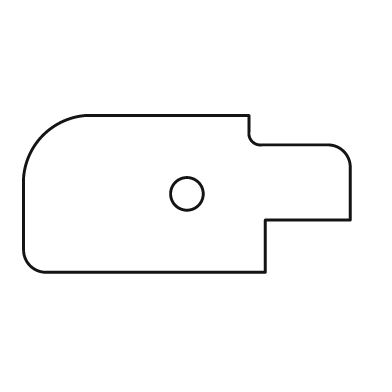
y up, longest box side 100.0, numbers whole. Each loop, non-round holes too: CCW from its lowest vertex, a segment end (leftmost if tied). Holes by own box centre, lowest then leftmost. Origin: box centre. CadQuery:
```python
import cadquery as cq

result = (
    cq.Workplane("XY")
    .moveTo(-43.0, -24.0)
    .lineTo(24.0, -24.0)
    .lineTo(24.0, -8.0)
    .lineTo(50.0, -8.0)
    .lineTo(50.0, 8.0)
    .threePointArc((48.0, 13.0), (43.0, 15.0))
    .lineTo(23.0, 15.0)
    .threePointArc((20.0, 16.0), (19.0, 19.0))
    .lineTo(19.0, 24.0)
    .lineTo(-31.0, 24.0)
    .threePointArc((-44.0, 18.0), (-50.0, 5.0))
    .lineTo(-50.0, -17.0)
    .threePointArc((-48.0, -22.0), (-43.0, -24.0))
    .close()
    .moveTo(0.0, 0.0)
    .circle(5.0)
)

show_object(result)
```